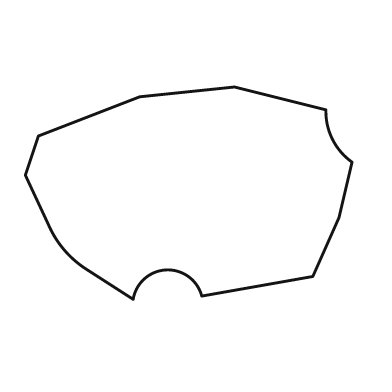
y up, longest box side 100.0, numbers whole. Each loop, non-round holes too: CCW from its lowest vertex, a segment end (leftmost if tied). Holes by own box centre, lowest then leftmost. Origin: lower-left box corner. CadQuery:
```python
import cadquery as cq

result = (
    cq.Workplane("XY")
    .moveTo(33.0, 0.0)
    .threePointArc((43.0, 9.0), (54.0, 1.0))
    .lineTo(88.0, 7.0)
    .lineTo(96.0, 25.0)
    .lineTo(100.0, 42.0)
    .threePointArc((94.0, 49.0), (92.0, 58.0))
    .lineTo(64.0, 65.0)
    .lineTo(35.0, 62.0)
    .lineTo(4.0, 50.0)
    .lineTo(0.0, 38.0)
    .lineTo(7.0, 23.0)
    .threePointArc((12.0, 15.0), (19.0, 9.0))
    .close()
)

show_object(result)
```